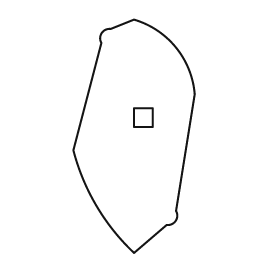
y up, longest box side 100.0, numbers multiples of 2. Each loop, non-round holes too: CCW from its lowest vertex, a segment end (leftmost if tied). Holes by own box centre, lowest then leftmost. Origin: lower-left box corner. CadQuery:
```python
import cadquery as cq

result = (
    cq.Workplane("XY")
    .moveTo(26.0, 0.0)
    .lineTo(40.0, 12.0)
    .threePointArc((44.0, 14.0), (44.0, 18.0))
    .lineTo(52.0, 68.0)
    .threePointArc((44.0, 88.0), (26.0, 100.0))
    .lineTo(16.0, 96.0)
    .threePointArc((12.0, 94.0), (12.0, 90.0))
    .lineTo(0.0, 44.0)
    .threePointArc((10.0, 20.0), (26.0, 0.0))
    .close()
    .moveTo(26.0, 54.0)
    .lineTo(34.0, 54.0)
    .lineTo(34.0, 62.0)
    .lineTo(26.0, 62.0)
    .close()
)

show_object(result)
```